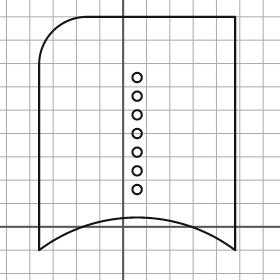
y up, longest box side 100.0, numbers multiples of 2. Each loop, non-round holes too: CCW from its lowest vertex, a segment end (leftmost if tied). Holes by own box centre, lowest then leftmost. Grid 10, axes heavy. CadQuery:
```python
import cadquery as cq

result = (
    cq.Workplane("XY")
    .moveTo(-36.0, -10.0)
    .threePointArc((6.0, 4.0), (48.0, -10.0))
    .lineTo(48.0, 90.0)
    .lineTo(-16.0, 90.0)
    .threePointArc((-30.0, 84.0), (-36.0, 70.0))
    .close()
    .moveTo(6.0, 16.0)
    .circle(2.0)
    .moveTo(6.0, 24.0)
    .circle(2.0)
    .moveTo(6.0, 32.0)
    .circle(2.0)
    .moveTo(6.0, 40.0)
    .circle(2.0)
    .moveTo(6.0, 48.0)
    .circle(2.0)
    .moveTo(6.0, 56.0)
    .circle(2.0)
    .moveTo(6.0, 64.0)
    .circle(2.0)
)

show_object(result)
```